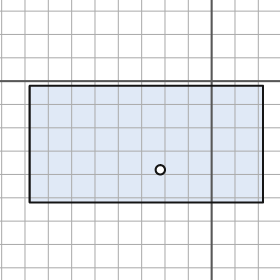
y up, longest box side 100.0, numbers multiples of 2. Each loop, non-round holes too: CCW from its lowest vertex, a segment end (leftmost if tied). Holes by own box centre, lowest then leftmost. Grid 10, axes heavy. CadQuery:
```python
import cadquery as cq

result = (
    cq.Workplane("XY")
    .moveTo(-78.0, -52.0)
    .lineTo(22.0, -52.0)
    .lineTo(22.0, -2.0)
    .lineTo(-78.0, -2.0)
    .close()
    .moveTo(-22.0, -38.0)
    .circle(2.0)
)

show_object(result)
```